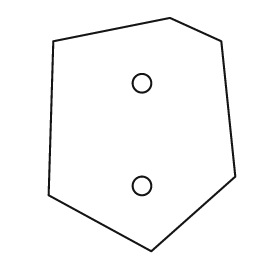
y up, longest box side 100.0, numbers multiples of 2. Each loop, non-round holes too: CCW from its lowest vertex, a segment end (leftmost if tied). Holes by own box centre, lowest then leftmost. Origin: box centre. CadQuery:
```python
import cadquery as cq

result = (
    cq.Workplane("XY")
    .moveTo(4.0, -50.0)
    .lineTo(40.0, -18.0)
    .lineTo(34.0, 40.0)
    .lineTo(12.0, 50.0)
    .lineTo(-38.0, 40.0)
    .lineTo(-40.0, -26.0)
    .close()
    .moveTo(0.0, -22.0)
    .circle(4.0)
    .moveTo(0.0, 22.0)
    .circle(4.0)
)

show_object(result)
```